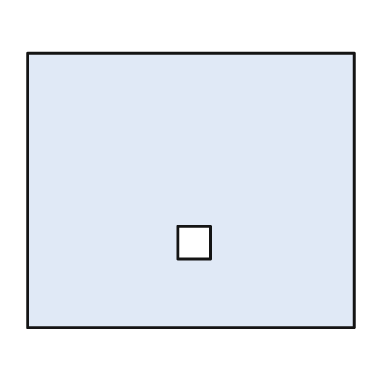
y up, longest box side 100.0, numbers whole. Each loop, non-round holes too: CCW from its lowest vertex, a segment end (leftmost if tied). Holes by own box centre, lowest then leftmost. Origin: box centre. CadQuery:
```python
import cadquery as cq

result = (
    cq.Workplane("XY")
    .moveTo(-50.0, -42.0)
    .lineTo(50.0, -42.0)
    .lineTo(50.0, 42.0)
    .lineTo(-50.0, 42.0)
    .close()
    .moveTo(-4.0, -21.0)
    .lineTo(6.0, -21.0)
    .lineTo(6.0, -11.0)
    .lineTo(-4.0, -11.0)
    .close()
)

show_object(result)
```